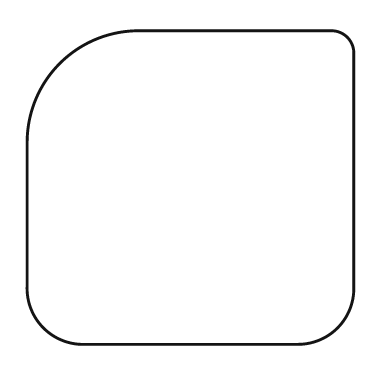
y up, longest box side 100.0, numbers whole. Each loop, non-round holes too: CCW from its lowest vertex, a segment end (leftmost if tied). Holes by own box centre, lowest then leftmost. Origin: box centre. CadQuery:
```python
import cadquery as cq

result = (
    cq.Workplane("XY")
    .moveTo(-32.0, -48.0)
    .lineTo(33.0, -48.0)
    .threePointArc((45.0, -43.0), (50.0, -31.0))
    .lineTo(50.0, 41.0)
    .threePointArc((48.0, 46.0), (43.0, 48.0))
    .lineTo(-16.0, 48.0)
    .threePointArc((-40.0, 38.0), (-50.0, 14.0))
    .lineTo(-50.0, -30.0)
    .threePointArc((-45.0, -43.0), (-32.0, -48.0))
    .close()
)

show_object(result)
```